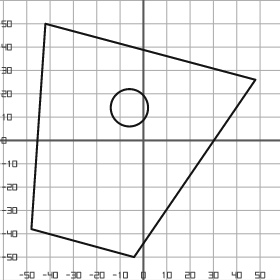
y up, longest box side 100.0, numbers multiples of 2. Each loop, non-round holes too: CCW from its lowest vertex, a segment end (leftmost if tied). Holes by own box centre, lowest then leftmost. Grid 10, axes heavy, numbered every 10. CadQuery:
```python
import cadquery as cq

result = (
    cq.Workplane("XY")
    .moveTo(-4.0, -50.0)
    .lineTo(48.0, 26.0)
    .lineTo(-42.0, 50.0)
    .lineTo(-48.0, -38.0)
    .close()
    .moveTo(-6.0, 14.0)
    .circle(8.0)
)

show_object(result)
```